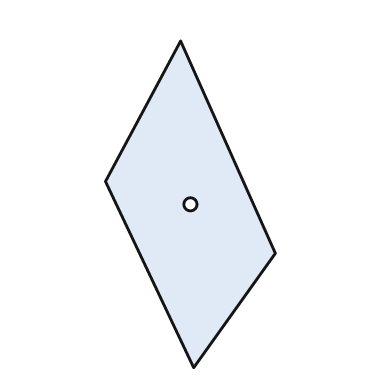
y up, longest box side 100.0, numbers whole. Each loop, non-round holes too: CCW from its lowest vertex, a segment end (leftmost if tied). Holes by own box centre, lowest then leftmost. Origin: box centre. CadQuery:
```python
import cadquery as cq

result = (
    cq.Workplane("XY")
    .moveTo(1.0, -50.0)
    .lineTo(26.0, -15.0)
    .lineTo(-3.0, 50.0)
    .lineTo(-26.0, 7.0)
    .close()
    .moveTo(0.0, 0.0)
    .circle(2.0)
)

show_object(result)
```